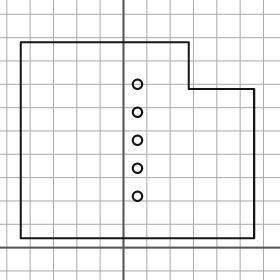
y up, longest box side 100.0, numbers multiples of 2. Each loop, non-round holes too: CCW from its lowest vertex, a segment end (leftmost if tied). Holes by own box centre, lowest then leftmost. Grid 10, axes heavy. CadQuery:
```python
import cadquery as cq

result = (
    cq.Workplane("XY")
    .moveTo(-44.0, 4.0)
    .lineTo(56.0, 4.0)
    .lineTo(56.0, 68.0)
    .lineTo(28.0, 68.0)
    .lineTo(28.0, 88.0)
    .lineTo(-44.0, 88.0)
    .close()
    .moveTo(6.0, 22.0)
    .circle(2.0)
    .moveTo(6.0, 34.0)
    .circle(2.0)
    .moveTo(6.0, 46.0)
    .circle(2.0)
    .moveTo(6.0, 58.0)
    .circle(2.0)
    .moveTo(6.0, 70.0)
    .circle(2.0)
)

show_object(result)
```